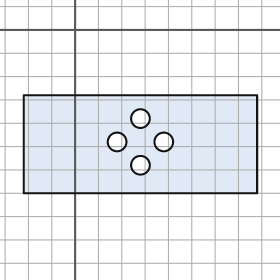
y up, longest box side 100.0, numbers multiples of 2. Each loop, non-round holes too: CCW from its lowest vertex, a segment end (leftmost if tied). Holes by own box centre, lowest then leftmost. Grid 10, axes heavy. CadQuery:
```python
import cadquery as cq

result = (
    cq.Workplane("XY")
    .moveTo(-22.0, -70.0)
    .lineTo(78.0, -70.0)
    .lineTo(78.0, -28.0)
    .lineTo(-22.0, -28.0)
    .close()
    .moveTo(28.0, -58.0)
    .circle(4.0)
    .moveTo(18.0, -48.0)
    .circle(4.0)
    .moveTo(38.0, -48.0)
    .circle(4.0)
    .moveTo(28.0, -38.0)
    .circle(4.0)
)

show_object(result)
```